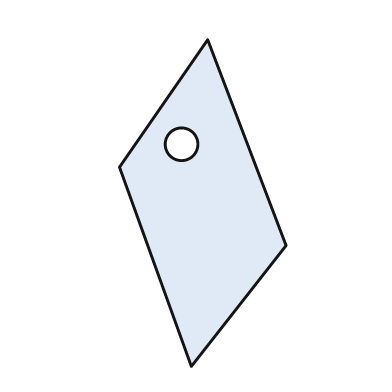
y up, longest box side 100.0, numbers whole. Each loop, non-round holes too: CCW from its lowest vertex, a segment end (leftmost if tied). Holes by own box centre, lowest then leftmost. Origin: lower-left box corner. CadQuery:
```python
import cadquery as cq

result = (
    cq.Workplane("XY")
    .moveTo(22.0, 0.0)
    .lineTo(51.0, 37.0)
    .lineTo(27.0, 100.0)
    .lineTo(0.0, 61.0)
    .close()
    .moveTo(19.0, 68.0)
    .circle(5.0)
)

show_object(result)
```